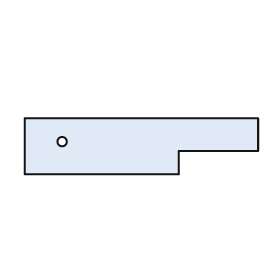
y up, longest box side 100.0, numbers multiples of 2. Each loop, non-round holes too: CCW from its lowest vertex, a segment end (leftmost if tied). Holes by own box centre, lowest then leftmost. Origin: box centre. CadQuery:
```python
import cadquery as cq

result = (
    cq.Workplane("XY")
    .moveTo(-50.0, -12.0)
    .lineTo(16.0, -12.0)
    .lineTo(16.0, -2.0)
    .lineTo(50.0, -2.0)
    .lineTo(50.0, 12.0)
    .lineTo(-50.0, 12.0)
    .close()
    .moveTo(-34.0, 2.0)
    .circle(2.0)
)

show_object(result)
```